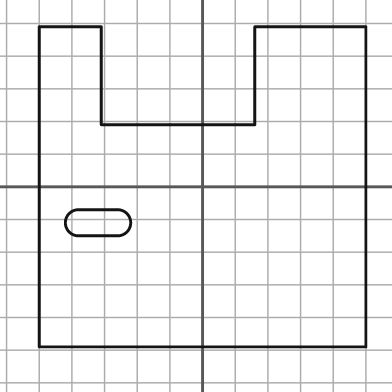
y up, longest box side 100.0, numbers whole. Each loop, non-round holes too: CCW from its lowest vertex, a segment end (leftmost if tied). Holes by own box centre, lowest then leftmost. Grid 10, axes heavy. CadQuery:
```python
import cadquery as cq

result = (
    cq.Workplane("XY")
    .moveTo(-50.0, -49.0)
    .lineTo(50.0, -49.0)
    .lineTo(50.0, 49.0)
    .lineTo(16.0, 49.0)
    .lineTo(16.0, 19.0)
    .lineTo(-31.0, 19.0)
    .lineTo(-31.0, 49.0)
    .lineTo(-50.0, 49.0)
    .close()
    .moveTo(-38.0, -15.0)
    .lineTo(-26.0, -15.0)
    .threePointArc((-22.0, -11.0), (-26.0, -7.0))
    .lineTo(-38.0, -7.0)
    .threePointArc((-42.0, -11.0), (-38.0, -15.0))
    .close()
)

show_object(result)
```